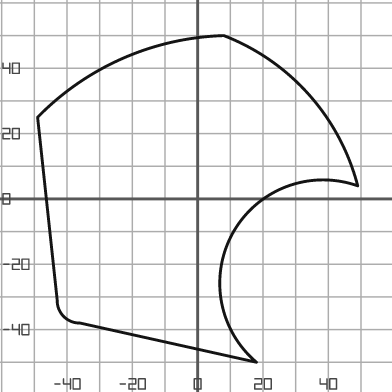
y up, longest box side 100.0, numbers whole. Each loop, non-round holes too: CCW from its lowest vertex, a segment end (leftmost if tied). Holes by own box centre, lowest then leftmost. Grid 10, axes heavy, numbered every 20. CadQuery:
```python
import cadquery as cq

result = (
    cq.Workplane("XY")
    .moveTo(18.0, -50.0)
    .threePointArc((11.0, -10.0), (49.0, 4.0))
    .threePointArc((34.0, 32.0), (8.0, 50.0))
    .threePointArc((-23.0, 43.0), (-49.0, 25.0))
    .lineTo(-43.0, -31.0)
    .threePointArc((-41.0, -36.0), (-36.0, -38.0))
    .close()
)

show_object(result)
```